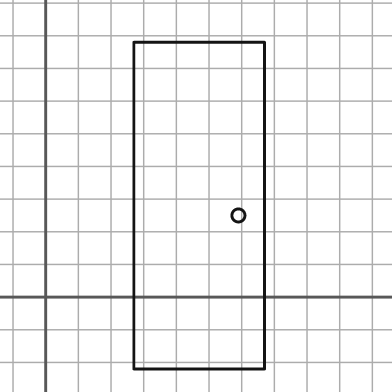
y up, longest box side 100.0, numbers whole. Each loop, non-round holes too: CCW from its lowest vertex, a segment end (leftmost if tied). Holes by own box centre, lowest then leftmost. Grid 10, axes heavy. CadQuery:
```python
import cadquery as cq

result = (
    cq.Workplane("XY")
    .moveTo(27.0, -22.0)
    .lineTo(67.0, -22.0)
    .lineTo(67.0, 78.0)
    .lineTo(27.0, 78.0)
    .close()
    .moveTo(59.0, 25.0)
    .circle(2.0)
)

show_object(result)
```